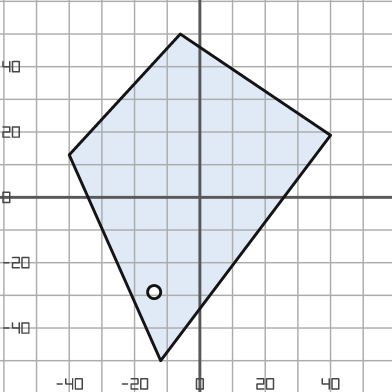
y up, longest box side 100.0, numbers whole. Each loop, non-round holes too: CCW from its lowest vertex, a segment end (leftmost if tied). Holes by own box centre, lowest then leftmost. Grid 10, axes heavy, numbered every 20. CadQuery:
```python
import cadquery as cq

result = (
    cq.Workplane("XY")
    .moveTo(-12.0, -50.0)
    .lineTo(40.0, 19.0)
    .lineTo(-6.0, 50.0)
    .lineTo(-40.0, 13.0)
    .close()
    .moveTo(-14.0, -29.0)
    .circle(2.0)
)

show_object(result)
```